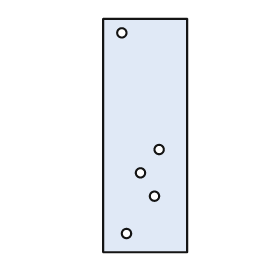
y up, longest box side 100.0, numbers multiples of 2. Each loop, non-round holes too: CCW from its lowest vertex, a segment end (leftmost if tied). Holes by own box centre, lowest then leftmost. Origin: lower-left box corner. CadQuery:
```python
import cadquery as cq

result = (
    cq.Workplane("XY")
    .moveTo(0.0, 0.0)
    .lineTo(36.0, 0.0)
    .lineTo(36.0, 100.0)
    .lineTo(0.0, 100.0)
    .close()
    .moveTo(10.0, 8.0)
    .circle(2.0)
    .moveTo(22.0, 24.0)
    .circle(2.0)
    .moveTo(16.0, 34.0)
    .circle(2.0)
    .moveTo(24.0, 44.0)
    .circle(2.0)
    .moveTo(8.0, 94.0)
    .circle(2.0)
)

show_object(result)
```